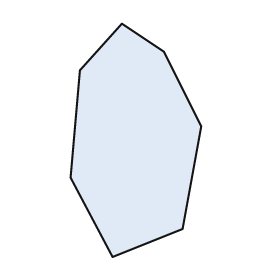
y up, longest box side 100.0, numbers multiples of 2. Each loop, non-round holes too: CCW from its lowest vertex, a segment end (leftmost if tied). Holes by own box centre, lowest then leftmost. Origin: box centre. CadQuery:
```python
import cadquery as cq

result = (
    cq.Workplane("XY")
    .moveTo(-10.0, -50.0)
    .lineTo(20.0, -38.0)
    .lineTo(28.0, 6.0)
    .lineTo(12.0, 38.0)
    .lineTo(-6.0, 50.0)
    .lineTo(-24.0, 30.0)
    .lineTo(-28.0, -16.0)
    .close()
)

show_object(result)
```